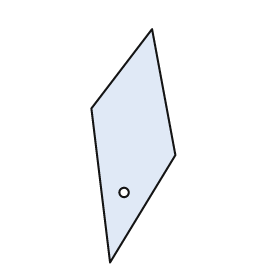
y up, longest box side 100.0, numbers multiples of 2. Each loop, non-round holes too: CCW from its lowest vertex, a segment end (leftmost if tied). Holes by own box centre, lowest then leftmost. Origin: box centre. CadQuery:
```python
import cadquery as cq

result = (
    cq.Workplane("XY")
    .moveTo(-10.0, -50.0)
    .lineTo(18.0, -4.0)
    .lineTo(8.0, 50.0)
    .lineTo(-18.0, 16.0)
    .close()
    .moveTo(-4.0, -20.0)
    .circle(2.0)
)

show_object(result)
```